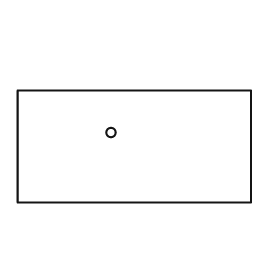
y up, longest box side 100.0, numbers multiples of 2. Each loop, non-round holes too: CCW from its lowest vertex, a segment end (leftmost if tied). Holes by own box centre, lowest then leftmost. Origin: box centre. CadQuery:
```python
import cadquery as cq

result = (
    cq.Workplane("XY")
    .moveTo(-50.0, -24.0)
    .lineTo(50.0, -24.0)
    .lineTo(50.0, 24.0)
    .lineTo(-50.0, 24.0)
    .close()
    .moveTo(-10.0, 6.0)
    .circle(2.0)
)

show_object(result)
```